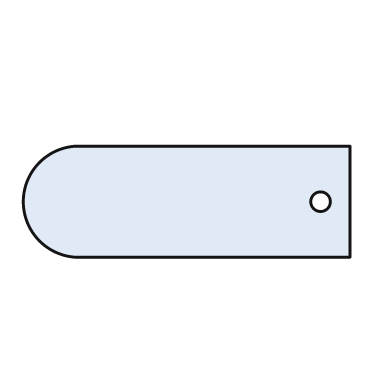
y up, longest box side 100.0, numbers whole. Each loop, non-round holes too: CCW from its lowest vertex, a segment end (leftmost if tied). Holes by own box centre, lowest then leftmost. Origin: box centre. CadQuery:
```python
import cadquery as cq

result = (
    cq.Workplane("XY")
    .moveTo(-34.0, -17.0)
    .lineTo(50.0, -17.0)
    .lineTo(50.0, 17.0)
    .lineTo(-34.0, 17.0)
    .threePointArc((-50.0, 0.0), (-34.0, -17.0))
    .close()
    .moveTo(41.0, 0.0)
    .circle(3.0)
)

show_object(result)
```